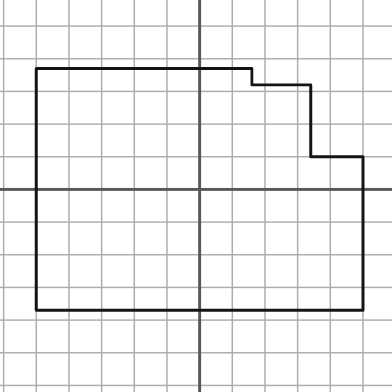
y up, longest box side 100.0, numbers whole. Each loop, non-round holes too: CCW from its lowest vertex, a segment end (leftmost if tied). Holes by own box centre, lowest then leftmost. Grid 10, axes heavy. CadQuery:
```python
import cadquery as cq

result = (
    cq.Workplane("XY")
    .moveTo(-50.0, -37.0)
    .lineTo(50.0, -37.0)
    .lineTo(50.0, 10.0)
    .lineTo(34.0, 10.0)
    .lineTo(34.0, 32.0)
    .lineTo(16.0, 32.0)
    .lineTo(16.0, 37.0)
    .lineTo(-50.0, 37.0)
    .close()
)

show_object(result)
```